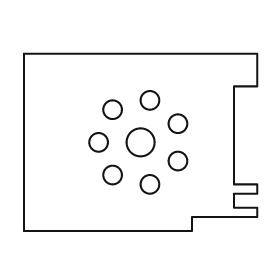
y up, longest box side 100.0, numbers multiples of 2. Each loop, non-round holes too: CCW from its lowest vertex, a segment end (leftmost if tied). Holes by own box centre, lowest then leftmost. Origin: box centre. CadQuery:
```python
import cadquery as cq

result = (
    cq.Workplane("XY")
    .moveTo(-50.0, -38.0)
    .lineTo(22.0, -38.0)
    .lineTo(22.0, -32.0)
    .lineTo(50.0, -32.0)
    .lineTo(50.0, -28.0)
    .lineTo(40.0, -28.0)
    .lineTo(40.0, -22.0)
    .lineTo(50.0, -22.0)
    .lineTo(50.0, -18.0)
    .lineTo(40.0, -18.0)
    .lineTo(40.0, 24.0)
    .lineTo(50.0, 24.0)
    .lineTo(50.0, 38.0)
    .lineTo(-50.0, 38.0)
    .close()
    .moveTo(4.0, -18.0)
    .circle(4.0)
    .moveTo(-12.0, -14.0)
    .circle(4.0)
    .moveTo(16.0, -8.0)
    .circle(4.0)
    .moveTo(-18.0, 0.0)
    .circle(4.0)
    .moveTo(0.0, 0.0)
    .circle(6.0)
    .moveTo(16.0, 8.0)
    .circle(4.0)
    .moveTo(-12.0, 14.0)
    .circle(4.0)
    .moveTo(4.0, 18.0)
    .circle(4.0)
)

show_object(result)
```